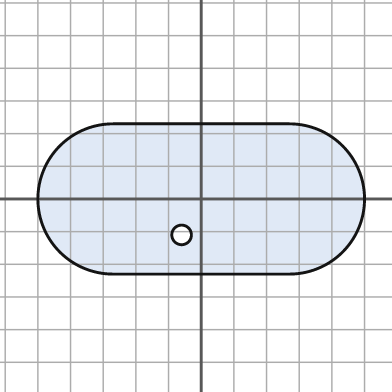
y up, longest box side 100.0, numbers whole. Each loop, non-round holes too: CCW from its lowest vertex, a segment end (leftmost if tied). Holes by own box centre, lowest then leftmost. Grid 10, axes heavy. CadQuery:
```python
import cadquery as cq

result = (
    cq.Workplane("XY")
    .moveTo(-27.0, -23.0)
    .lineTo(27.0, -23.0)
    .threePointArc((50.0, 0.0), (27.0, 23.0))
    .lineTo(-27.0, 23.0)
    .threePointArc((-50.0, 0.0), (-27.0, -23.0))
    .close()
    .moveTo(-6.0, -11.0)
    .circle(3.0)
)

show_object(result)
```